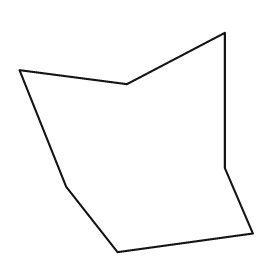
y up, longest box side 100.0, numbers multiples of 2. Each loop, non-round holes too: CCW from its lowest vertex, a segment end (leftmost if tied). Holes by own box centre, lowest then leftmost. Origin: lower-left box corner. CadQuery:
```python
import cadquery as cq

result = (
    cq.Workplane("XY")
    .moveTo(42.0, 0.0)
    .lineTo(100.0, 8.0)
    .lineTo(88.0, 36.0)
    .lineTo(88.0, 94.0)
    .lineTo(46.0, 72.0)
    .lineTo(0.0, 78.0)
    .lineTo(20.0, 28.0)
    .close()
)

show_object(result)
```